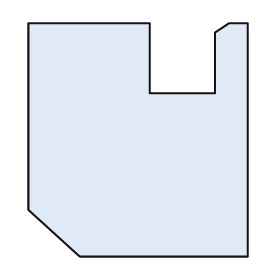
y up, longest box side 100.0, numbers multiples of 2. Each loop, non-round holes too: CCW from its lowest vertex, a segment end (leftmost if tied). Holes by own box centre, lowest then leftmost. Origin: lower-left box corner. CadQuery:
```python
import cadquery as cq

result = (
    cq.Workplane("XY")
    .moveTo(22.0, 0.0)
    .lineTo(94.0, 0.0)
    .lineTo(94.0, 100.0)
    .lineTo(86.0, 100.0)
    .lineTo(80.0, 96.0)
    .lineTo(80.0, 70.0)
    .lineTo(52.0, 70.0)
    .lineTo(52.0, 100.0)
    .lineTo(0.0, 100.0)
    .lineTo(0.0, 20.0)
    .close()
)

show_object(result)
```